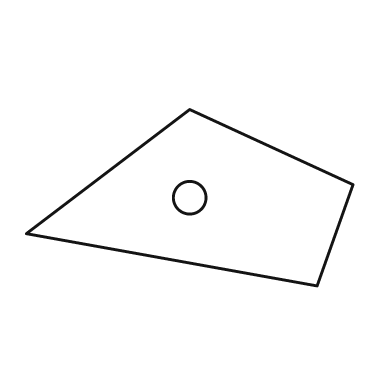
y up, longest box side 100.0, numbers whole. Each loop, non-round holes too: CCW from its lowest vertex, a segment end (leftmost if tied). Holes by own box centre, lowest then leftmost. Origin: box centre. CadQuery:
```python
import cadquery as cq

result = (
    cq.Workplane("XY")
    .moveTo(39.0, -27.0)
    .lineTo(50.0, 4.0)
    .lineTo(0.0, 27.0)
    .lineTo(-50.0, -11.0)
    .close()
    .moveTo(0.0, 0.0)
    .circle(5.0)
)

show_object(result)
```